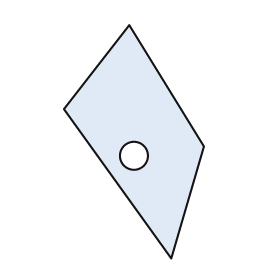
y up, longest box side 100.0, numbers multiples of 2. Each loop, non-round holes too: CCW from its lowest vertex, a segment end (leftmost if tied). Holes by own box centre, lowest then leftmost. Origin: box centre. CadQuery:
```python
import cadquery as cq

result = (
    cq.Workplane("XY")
    .moveTo(16.0, -50.0)
    .lineTo(30.0, -2.0)
    .lineTo(-2.0, 50.0)
    .lineTo(-30.0, 14.0)
    .close()
    .moveTo(0.0, -6.0)
    .circle(6.0)
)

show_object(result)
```